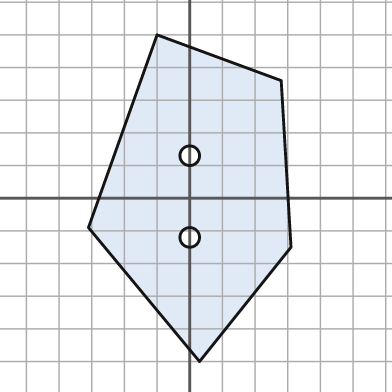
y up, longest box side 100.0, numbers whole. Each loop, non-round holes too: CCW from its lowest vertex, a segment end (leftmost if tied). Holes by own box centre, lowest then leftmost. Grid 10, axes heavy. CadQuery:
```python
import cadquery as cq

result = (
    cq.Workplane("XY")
    .moveTo(3.0, -50.0)
    .lineTo(31.0, -15.0)
    .lineTo(28.0, 36.0)
    .lineTo(-10.0, 50.0)
    .lineTo(-31.0, -9.0)
    .close()
    .moveTo(0.0, -12.0)
    .circle(3.0)
    .moveTo(0.0, 13.0)
    .circle(3.0)
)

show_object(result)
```